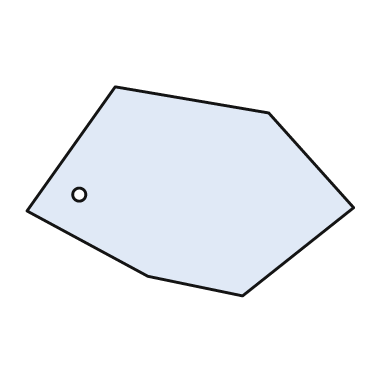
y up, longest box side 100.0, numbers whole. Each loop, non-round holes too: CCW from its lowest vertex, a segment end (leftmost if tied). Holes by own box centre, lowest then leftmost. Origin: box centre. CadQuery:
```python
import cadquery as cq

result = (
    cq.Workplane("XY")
    .moveTo(16.0, -32.0)
    .lineTo(50.0, -5.0)
    .lineTo(24.0, 24.0)
    .lineTo(-23.0, 32.0)
    .lineTo(-50.0, -6.0)
    .lineTo(-13.0, -26.0)
    .close()
    .moveTo(-34.0, -1.0)
    .circle(2.0)
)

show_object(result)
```